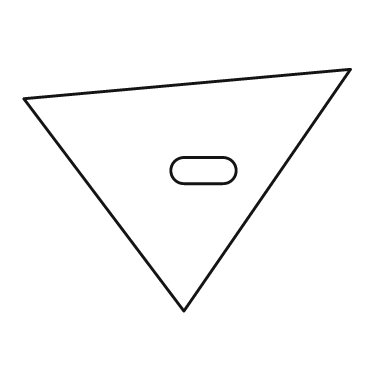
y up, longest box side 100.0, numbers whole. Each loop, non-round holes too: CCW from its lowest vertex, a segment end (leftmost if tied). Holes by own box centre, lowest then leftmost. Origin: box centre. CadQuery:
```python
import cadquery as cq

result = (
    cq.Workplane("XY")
    .moveTo(-1.0, -37.0)
    .lineTo(50.0, 37.0)
    .lineTo(-50.0, 28.0)
    .close()
    .moveTo(-1.0, 2.0)
    .lineTo(11.0, 2.0)
    .threePointArc((15.0, 6.0), (11.0, 10.0))
    .lineTo(-1.0, 10.0)
    .threePointArc((-5.0, 6.0), (-1.0, 2.0))
    .close()
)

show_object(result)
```